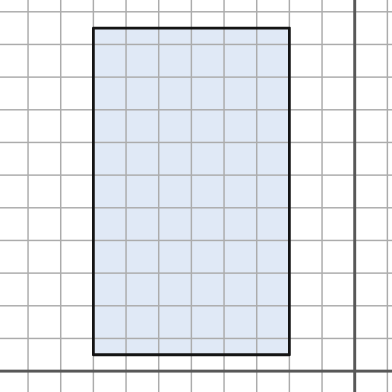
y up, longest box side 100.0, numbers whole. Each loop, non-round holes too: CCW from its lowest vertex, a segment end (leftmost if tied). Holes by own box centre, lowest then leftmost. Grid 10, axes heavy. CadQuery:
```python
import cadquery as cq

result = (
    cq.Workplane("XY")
    .moveTo(-80.0, 5.0)
    .lineTo(-20.0, 5.0)
    .lineTo(-20.0, 105.0)
    .lineTo(-80.0, 105.0)
    .close()
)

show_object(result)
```